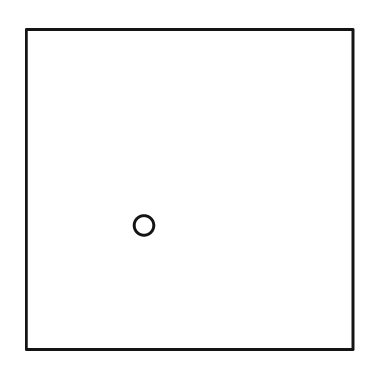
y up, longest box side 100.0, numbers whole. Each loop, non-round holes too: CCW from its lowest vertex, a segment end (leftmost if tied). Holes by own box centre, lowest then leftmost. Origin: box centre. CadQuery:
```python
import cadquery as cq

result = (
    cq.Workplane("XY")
    .moveTo(-50.0, -49.0)
    .lineTo(50.0, -49.0)
    .lineTo(50.0, 49.0)
    .lineTo(-50.0, 49.0)
    .close()
    .moveTo(-14.0, -11.0)
    .circle(3.0)
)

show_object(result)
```